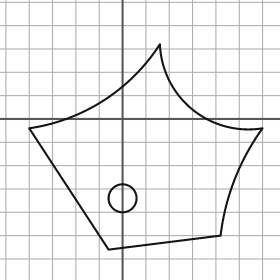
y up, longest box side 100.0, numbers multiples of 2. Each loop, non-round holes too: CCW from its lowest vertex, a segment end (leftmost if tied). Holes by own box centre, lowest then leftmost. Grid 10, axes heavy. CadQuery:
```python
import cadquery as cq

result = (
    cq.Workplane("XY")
    .moveTo(-6.0, -56.0)
    .lineTo(42.0, -50.0)
    .threePointArc((48.0, -26.0), (60.0, -4.0))
    .threePointArc((30.0, 4.0), (16.0, 32.0))
    .threePointArc((-8.0, 8.0), (-40.0, -4.0))
    .close()
    .moveTo(0.0, -34.0)
    .circle(6.0)
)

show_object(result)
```